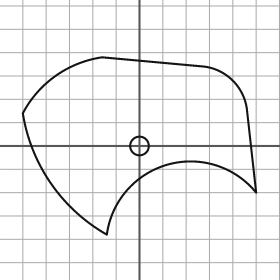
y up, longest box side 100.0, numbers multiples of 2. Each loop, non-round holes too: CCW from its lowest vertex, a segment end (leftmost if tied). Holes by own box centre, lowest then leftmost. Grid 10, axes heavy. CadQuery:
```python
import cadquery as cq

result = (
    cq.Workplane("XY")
    .moveTo(-14.0, -38.0)
    .threePointArc((12.0, -8.0), (50.0, -20.0))
    .lineTo(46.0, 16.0)
    .threePointArc((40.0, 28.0), (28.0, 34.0))
    .lineTo(-16.0, 38.0)
    .threePointArc((-36.0, 30.0), (-50.0, 14.0))
    .threePointArc((-38.0, -16.0), (-14.0, -38.0))
    .close()
    .moveTo(0.0, 0.0)
    .circle(4.0)
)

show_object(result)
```